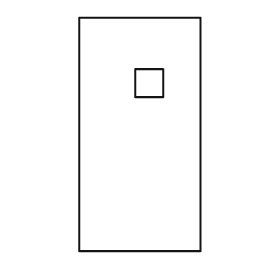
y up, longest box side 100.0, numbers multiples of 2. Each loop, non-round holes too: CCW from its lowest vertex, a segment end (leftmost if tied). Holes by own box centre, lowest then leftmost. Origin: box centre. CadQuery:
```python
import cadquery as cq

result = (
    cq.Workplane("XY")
    .moveTo(-26.0, -50.0)
    .lineTo(26.0, -50.0)
    .lineTo(26.0, 50.0)
    .lineTo(-26.0, 50.0)
    .close()
    .moveTo(-2.0, 16.0)
    .lineTo(10.0, 16.0)
    .lineTo(10.0, 28.0)
    .lineTo(-2.0, 28.0)
    .close()
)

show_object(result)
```